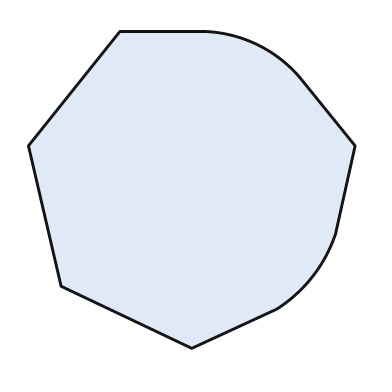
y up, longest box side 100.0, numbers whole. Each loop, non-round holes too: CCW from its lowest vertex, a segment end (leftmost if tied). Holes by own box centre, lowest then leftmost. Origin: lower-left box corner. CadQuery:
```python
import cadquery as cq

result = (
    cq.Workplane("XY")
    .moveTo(50.0, 0.0)
    .lineTo(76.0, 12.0)
    .threePointArc((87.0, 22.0), (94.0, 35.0))
    .lineTo(100.0, 62.0)
    .lineTo(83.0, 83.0)
    .threePointArc((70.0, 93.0), (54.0, 97.0))
    .lineTo(28.0, 97.0)
    .lineTo(0.0, 62.0)
    .lineTo(10.0, 19.0)
    .close()
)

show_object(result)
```